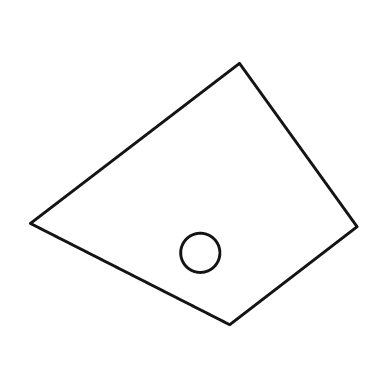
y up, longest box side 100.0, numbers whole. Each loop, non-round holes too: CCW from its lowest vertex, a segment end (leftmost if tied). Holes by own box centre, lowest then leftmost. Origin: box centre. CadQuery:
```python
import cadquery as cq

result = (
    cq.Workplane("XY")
    .moveTo(11.0, -40.0)
    .lineTo(50.0, -10.0)
    .lineTo(14.0, 40.0)
    .lineTo(-50.0, -9.0)
    .close()
    .moveTo(2.0, -18.0)
    .circle(6.0)
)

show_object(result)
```